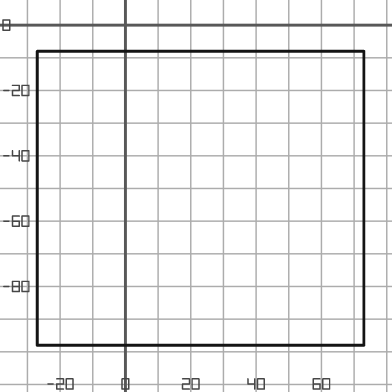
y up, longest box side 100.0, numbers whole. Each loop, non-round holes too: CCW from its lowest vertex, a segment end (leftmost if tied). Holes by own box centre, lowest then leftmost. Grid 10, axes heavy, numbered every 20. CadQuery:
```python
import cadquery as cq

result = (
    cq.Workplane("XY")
    .moveTo(-27.0, -98.0)
    .lineTo(73.0, -98.0)
    .lineTo(73.0, -8.0)
    .lineTo(-27.0, -8.0)
    .close()
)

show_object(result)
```